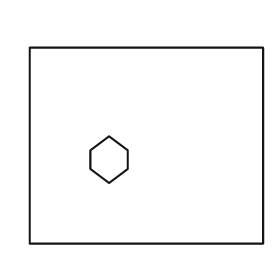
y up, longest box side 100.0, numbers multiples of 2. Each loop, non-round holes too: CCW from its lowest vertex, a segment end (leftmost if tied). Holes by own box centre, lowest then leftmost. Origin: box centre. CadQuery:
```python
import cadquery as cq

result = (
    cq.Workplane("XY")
    .moveTo(-50.0, -42.0)
    .lineTo(50.0, -42.0)
    .lineTo(50.0, 42.0)
    .lineTo(-50.0, 42.0)
    .close()
    .moveTo(-16.0, -16.0)
    .lineTo(-8.0, -10.0)
    .lineTo(-8.0, -2.0)
    .lineTo(-16.0, 4.0)
    .lineTo(-24.0, -2.0)
    .lineTo(-24.0, -10.0)
    .close()
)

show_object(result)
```